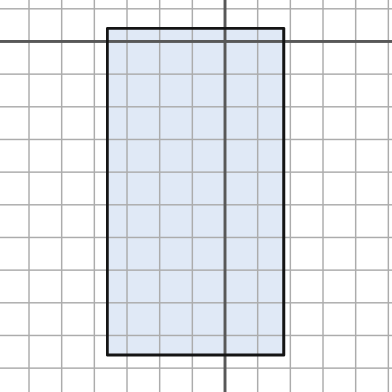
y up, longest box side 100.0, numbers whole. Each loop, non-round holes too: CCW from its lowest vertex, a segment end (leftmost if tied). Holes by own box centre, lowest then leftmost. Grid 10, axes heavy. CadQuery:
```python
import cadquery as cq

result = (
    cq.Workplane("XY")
    .moveTo(-36.0, -96.0)
    .lineTo(18.0, -96.0)
    .lineTo(18.0, 4.0)
    .lineTo(-36.0, 4.0)
    .close()
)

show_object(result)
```